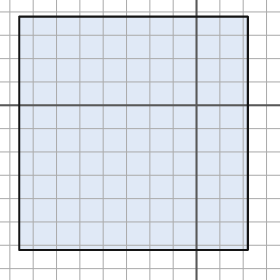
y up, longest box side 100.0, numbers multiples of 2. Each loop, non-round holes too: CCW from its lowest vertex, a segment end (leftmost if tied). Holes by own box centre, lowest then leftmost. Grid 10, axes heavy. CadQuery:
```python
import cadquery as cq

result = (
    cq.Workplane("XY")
    .moveTo(-76.0, -62.0)
    .lineTo(22.0, -62.0)
    .lineTo(22.0, 38.0)
    .lineTo(-76.0, 38.0)
    .close()
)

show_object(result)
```